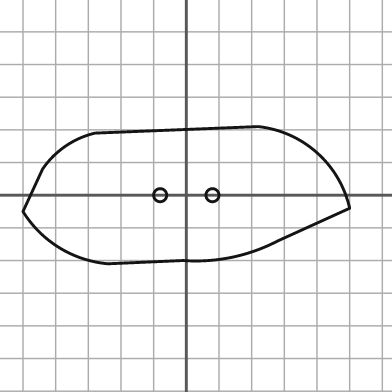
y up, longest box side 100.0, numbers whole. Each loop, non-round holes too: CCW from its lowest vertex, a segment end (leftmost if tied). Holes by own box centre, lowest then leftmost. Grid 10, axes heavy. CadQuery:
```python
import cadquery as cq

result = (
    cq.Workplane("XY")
    .moveTo(-24.0, -21.0)
    .lineTo(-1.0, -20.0)
    .threePointArc((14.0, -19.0), (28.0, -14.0))
    .lineTo(50.0, -4.0)
    .threePointArc((40.0, 13.0), (22.0, 21.0))
    .lineTo(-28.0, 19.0)
    .threePointArc((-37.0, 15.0), (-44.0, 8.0))
    .lineTo(-50.0, -5.0)
    .threePointArc((-39.0, -16.0), (-24.0, -21.0))
    .close()
    .moveTo(-8.0, 0.0)
    .circle(2.0)
    .moveTo(8.0, 0.0)
    .circle(2.0)
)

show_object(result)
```